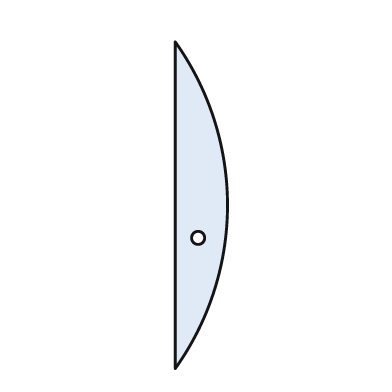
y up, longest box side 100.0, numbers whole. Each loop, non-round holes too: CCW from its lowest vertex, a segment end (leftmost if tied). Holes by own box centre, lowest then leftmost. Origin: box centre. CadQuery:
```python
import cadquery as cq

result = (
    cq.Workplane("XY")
    .moveTo(-8.0, -50.0)
    .threePointArc((8.0, 0.0), (-8.0, 50.0))
    .close()
    .moveTo(-1.0, -10.0)
    .circle(2.0)
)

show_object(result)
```